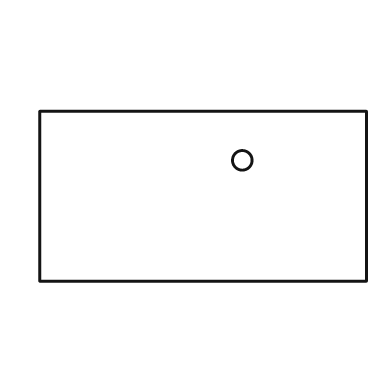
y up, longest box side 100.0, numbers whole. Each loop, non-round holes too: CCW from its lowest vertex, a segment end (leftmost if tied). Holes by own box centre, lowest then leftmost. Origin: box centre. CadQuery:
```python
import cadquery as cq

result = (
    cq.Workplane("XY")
    .moveTo(-50.0, -26.0)
    .lineTo(50.0, -26.0)
    .lineTo(50.0, 26.0)
    .lineTo(-50.0, 26.0)
    .close()
    .moveTo(12.0, 11.0)
    .circle(3.0)
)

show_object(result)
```